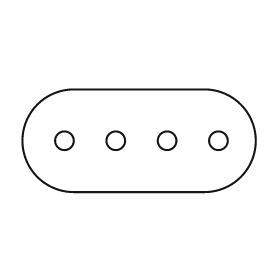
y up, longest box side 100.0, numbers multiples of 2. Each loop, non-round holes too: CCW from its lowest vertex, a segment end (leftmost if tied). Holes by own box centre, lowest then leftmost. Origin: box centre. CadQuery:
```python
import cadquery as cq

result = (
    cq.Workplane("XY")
    .moveTo(-28.0, -22.0)
    .lineTo(28.0, -22.0)
    .threePointArc((50.0, 0.0), (28.0, 22.0))
    .lineTo(-28.0, 22.0)
    .threePointArc((-50.0, 0.0), (-28.0, -22.0))
    .close()
    .moveTo(-32.0, 0.0)
    .circle(4.0)
    .moveTo(-10.0, 0.0)
    .circle(4.0)
    .moveTo(12.0, 0.0)
    .circle(4.0)
    .moveTo(34.0, 0.0)
    .circle(4.0)
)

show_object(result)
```